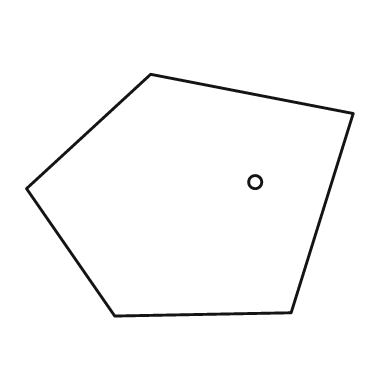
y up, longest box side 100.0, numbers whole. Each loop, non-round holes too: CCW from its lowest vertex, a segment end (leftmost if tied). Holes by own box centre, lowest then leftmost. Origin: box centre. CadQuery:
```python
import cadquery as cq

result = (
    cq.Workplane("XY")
    .moveTo(-23.0, -37.0)
    .lineTo(31.0, -36.0)
    .lineTo(50.0, 25.0)
    .lineTo(-12.0, 37.0)
    .lineTo(-50.0, 2.0)
    .close()
    .moveTo(20.0, 4.0)
    .circle(2.0)
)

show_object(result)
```